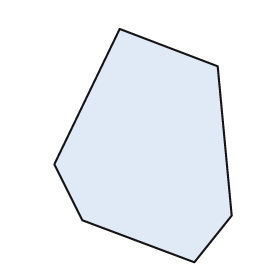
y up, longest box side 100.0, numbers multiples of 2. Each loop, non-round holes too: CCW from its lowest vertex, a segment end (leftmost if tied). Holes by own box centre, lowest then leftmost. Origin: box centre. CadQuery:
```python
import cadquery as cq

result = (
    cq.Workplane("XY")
    .moveTo(22.0, -50.0)
    .lineTo(38.0, -30.0)
    .lineTo(32.0, 34.0)
    .lineTo(-10.0, 50.0)
    .lineTo(-38.0, -8.0)
    .lineTo(-26.0, -32.0)
    .close()
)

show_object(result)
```